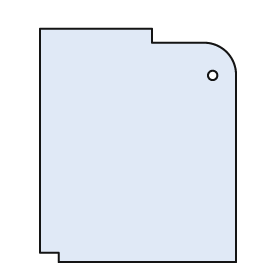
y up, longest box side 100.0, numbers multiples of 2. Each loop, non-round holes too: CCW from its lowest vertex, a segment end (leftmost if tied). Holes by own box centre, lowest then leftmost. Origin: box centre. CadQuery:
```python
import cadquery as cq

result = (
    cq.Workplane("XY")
    .moveTo(-34.0, -50.0)
    .lineTo(42.0, -50.0)
    .lineTo(42.0, 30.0)
    .threePointArc((38.0, 40.0), (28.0, 44.0))
    .lineTo(6.0, 44.0)
    .lineTo(6.0, 50.0)
    .lineTo(-42.0, 50.0)
    .lineTo(-42.0, -46.0)
    .lineTo(-34.0, -46.0)
    .close()
    .moveTo(32.0, 30.0)
    .circle(2.0)
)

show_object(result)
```